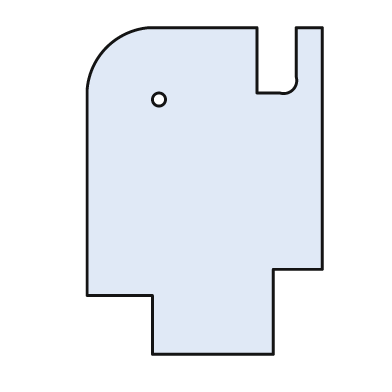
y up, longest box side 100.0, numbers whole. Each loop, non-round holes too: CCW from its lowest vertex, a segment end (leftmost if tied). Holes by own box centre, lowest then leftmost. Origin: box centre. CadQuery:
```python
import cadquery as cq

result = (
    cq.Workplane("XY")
    .moveTo(-16.0, -50.0)
    .lineTo(21.0, -50.0)
    .lineTo(21.0, -24.0)
    .lineTo(36.0, -24.0)
    .lineTo(36.0, 50.0)
    .lineTo(28.0, 50.0)
    .lineTo(28.0, 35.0)
    .threePointArc((27.0, 31.0), (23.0, 30.0))
    .lineTo(16.0, 30.0)
    .lineTo(16.0, 50.0)
    .lineTo(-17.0, 50.0)
    .threePointArc((-30.0, 44.0), (-36.0, 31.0))
    .lineTo(-36.0, -32.0)
    .lineTo(-16.0, -32.0)
    .close()
    .moveTo(-14.0, 28.0)
    .circle(2.0)
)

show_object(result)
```